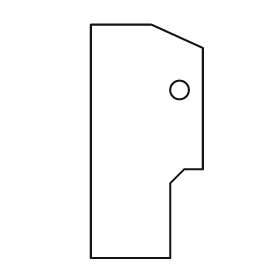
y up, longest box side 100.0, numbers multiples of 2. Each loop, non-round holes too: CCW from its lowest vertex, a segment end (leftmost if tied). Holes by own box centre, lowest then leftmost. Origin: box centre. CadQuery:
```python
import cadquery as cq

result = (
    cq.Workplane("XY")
    .moveTo(-24.0, -50.0)
    .lineTo(10.0, -50.0)
    .lineTo(10.0, -18.0)
    .lineTo(16.0, -12.0)
    .lineTo(24.0, -12.0)
    .lineTo(24.0, 40.0)
    .lineTo(2.0, 50.0)
    .lineTo(-24.0, 50.0)
    .close()
    .moveTo(14.0, 22.0)
    .circle(4.0)
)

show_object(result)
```